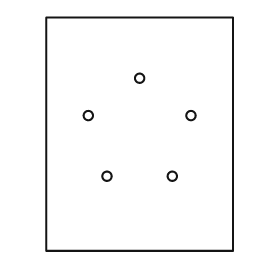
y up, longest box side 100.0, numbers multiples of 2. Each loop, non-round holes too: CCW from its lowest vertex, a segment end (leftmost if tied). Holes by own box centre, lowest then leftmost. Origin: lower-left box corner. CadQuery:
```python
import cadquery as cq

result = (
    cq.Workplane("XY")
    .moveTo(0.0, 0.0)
    .lineTo(80.0, 0.0)
    .lineTo(80.0, 100.0)
    .lineTo(0.0, 100.0)
    .close()
    .moveTo(26.0, 32.0)
    .circle(2.0)
    .moveTo(54.0, 32.0)
    .circle(2.0)
    .moveTo(18.0, 58.0)
    .circle(2.0)
    .moveTo(62.0, 58.0)
    .circle(2.0)
    .moveTo(40.0, 74.0)
    .circle(2.0)
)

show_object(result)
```